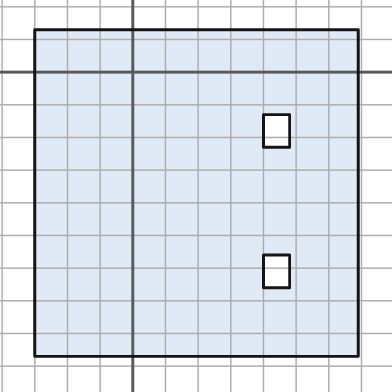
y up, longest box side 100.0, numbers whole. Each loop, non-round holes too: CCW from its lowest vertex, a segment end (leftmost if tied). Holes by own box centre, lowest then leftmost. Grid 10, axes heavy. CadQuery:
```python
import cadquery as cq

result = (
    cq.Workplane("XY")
    .moveTo(-30.0, -87.0)
    .lineTo(69.0, -87.0)
    .lineTo(69.0, 13.0)
    .lineTo(-30.0, 13.0)
    .close()
    .moveTo(40.0, -66.0)
    .lineTo(48.0, -66.0)
    .lineTo(48.0, -56.0)
    .lineTo(40.0, -56.0)
    .close()
    .moveTo(40.0, -23.0)
    .lineTo(48.0, -23.0)
    .lineTo(48.0, -13.0)
    .lineTo(40.0, -13.0)
    .close()
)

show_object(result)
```